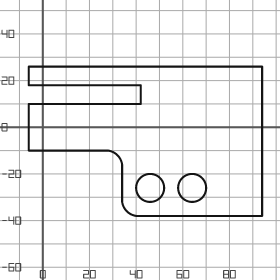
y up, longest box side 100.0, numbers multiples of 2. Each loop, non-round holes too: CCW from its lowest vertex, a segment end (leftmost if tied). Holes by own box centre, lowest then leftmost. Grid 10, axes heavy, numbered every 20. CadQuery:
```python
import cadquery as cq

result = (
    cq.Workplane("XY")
    .moveTo(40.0, -38.0)
    .lineTo(94.0, -38.0)
    .lineTo(94.0, 26.0)
    .lineTo(-6.0, 26.0)
    .lineTo(-6.0, 18.0)
    .lineTo(42.0, 18.0)
    .lineTo(42.0, 10.0)
    .lineTo(-6.0, 10.0)
    .lineTo(-6.0, -10.0)
    .lineTo(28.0, -10.0)
    .threePointArc((32.0, -12.0), (34.0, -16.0))
    .lineTo(34.0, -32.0)
    .threePointArc((36.0, -36.0), (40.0, -38.0))
    .close()
    .moveTo(46.0, -26.0)
    .circle(6.0)
    .moveTo(64.0, -26.0)
    .circle(6.0)
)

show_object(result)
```